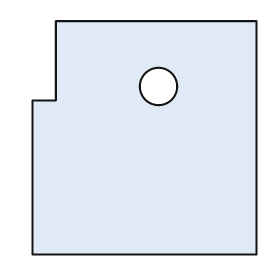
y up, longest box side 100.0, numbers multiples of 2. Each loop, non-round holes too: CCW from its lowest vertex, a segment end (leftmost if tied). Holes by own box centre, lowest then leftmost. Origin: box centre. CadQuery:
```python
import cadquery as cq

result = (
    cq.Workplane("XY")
    .moveTo(-48.0, -50.0)
    .lineTo(48.0, -50.0)
    .lineTo(48.0, 50.0)
    .lineTo(-38.0, 50.0)
    .lineTo(-38.0, 16.0)
    .lineTo(-48.0, 16.0)
    .close()
    .moveTo(6.0, 22.0)
    .circle(8.0)
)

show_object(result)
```